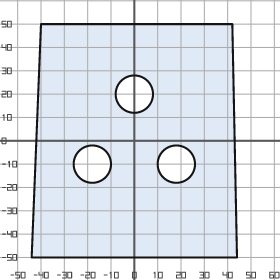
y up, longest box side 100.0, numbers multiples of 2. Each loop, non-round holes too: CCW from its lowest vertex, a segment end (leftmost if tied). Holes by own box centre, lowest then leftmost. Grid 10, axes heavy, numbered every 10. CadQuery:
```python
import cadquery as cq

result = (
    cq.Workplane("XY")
    .moveTo(-44.0, -50.0)
    .lineTo(44.0, -50.0)
    .lineTo(42.0, 50.0)
    .lineTo(-40.0, 50.0)
    .close()
    .moveTo(-18.0, -10.0)
    .circle(8.0)
    .moveTo(18.0, -10.0)
    .circle(8.0)
    .moveTo(0.0, 20.0)
    .circle(8.0)
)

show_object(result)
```